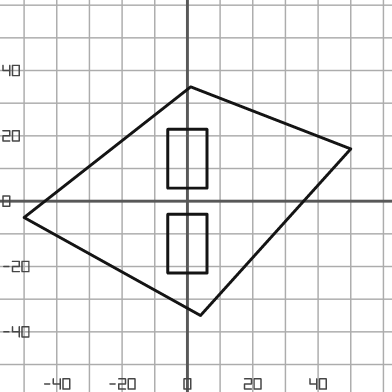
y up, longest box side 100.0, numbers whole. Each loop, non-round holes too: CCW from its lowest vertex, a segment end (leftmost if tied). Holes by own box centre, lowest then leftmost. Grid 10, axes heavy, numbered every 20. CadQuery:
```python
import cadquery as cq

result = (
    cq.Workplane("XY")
    .moveTo(4.0, -35.0)
    .lineTo(50.0, 16.0)
    .lineTo(1.0, 35.0)
    .lineTo(-50.0, -5.0)
    .close()
    .moveTo(-6.0, -22.0)
    .lineTo(6.0, -22.0)
    .lineTo(6.0, -4.0)
    .lineTo(-6.0, -4.0)
    .close()
    .moveTo(-6.0, 4.0)
    .lineTo(6.0, 4.0)
    .lineTo(6.0, 22.0)
    .lineTo(-6.0, 22.0)
    .close()
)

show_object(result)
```